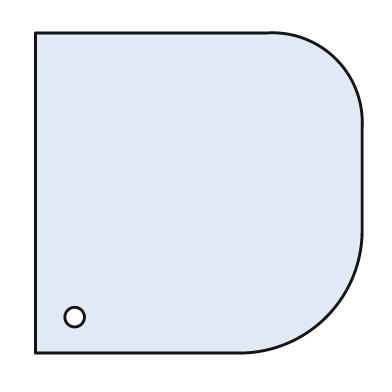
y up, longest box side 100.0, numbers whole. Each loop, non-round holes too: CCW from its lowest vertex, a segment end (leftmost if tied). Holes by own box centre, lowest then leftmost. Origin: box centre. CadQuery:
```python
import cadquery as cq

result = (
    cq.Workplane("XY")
    .moveTo(-50.0, -49.0)
    .lineTo(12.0, -49.0)
    .threePointArc((39.0, -38.0), (50.0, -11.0))
    .lineTo(50.0, 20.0)
    .threePointArc((42.0, 41.0), (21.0, 49.0))
    .lineTo(-50.0, 49.0)
    .close()
    .moveTo(-38.0, -38.0)
    .circle(3.0)
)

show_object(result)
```